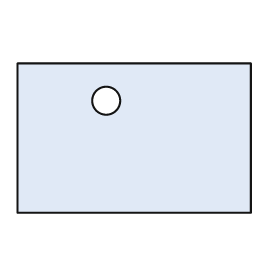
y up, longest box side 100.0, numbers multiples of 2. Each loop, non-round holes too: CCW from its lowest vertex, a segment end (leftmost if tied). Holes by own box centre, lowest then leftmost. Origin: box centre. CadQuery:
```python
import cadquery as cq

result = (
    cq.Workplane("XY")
    .moveTo(-50.0, -32.0)
    .lineTo(50.0, -32.0)
    .lineTo(50.0, 32.0)
    .lineTo(-50.0, 32.0)
    .close()
    .moveTo(-12.0, 16.0)
    .circle(6.0)
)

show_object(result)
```